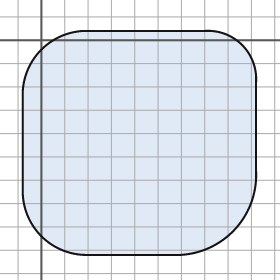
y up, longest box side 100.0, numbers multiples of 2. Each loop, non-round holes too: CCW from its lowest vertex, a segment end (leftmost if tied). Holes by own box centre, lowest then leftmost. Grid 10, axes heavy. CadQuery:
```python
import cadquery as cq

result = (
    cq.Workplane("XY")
    .moveTo(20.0, -92.0)
    .lineTo(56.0, -92.0)
    .threePointArc((82.0, -82.0), (92.0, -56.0))
    .lineTo(92.0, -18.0)
    .threePointArc((86.0, -2.0), (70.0, 4.0))
    .lineTo(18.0, 4.0)
    .threePointArc((0.0, -4.0), (-8.0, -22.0))
    .lineTo(-8.0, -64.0)
    .threePointArc((0.0, -84.0), (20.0, -92.0))
    .close()
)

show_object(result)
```